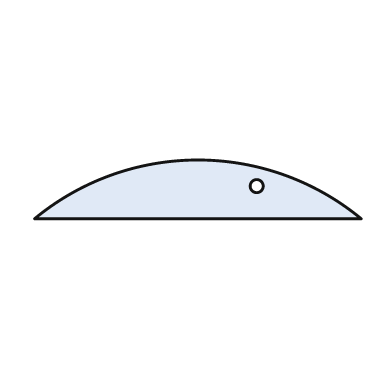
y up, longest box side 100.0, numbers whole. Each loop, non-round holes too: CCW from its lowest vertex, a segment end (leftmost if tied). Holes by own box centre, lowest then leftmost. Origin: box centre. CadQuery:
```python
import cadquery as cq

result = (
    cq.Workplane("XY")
    .moveTo(-50.0, -9.0)
    .lineTo(50.0, -9.0)
    .threePointArc((0.0, 9.0), (-50.0, -9.0))
    .close()
    .moveTo(18.0, 1.0)
    .circle(2.0)
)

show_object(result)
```